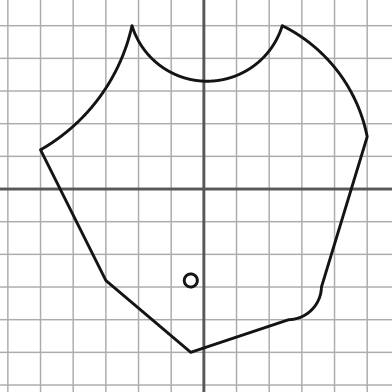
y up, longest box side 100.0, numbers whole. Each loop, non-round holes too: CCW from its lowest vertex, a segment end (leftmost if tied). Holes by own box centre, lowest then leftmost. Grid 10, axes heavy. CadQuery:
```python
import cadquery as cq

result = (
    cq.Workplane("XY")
    .moveTo(-4.0, -50.0)
    .lineTo(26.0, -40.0)
    .threePointArc((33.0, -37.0), (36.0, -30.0))
    .lineTo(50.0, 16.0)
    .threePointArc((41.0, 36.0), (24.0, 50.0))
    .threePointArc((1.0, 33.0), (-22.0, 50.0))
    .threePointArc((-32.0, 28.0), (-50.0, 12.0))
    .lineTo(-30.0, -28.0)
    .close()
    .moveTo(-4.0, -28.0)
    .circle(2.0)
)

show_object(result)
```